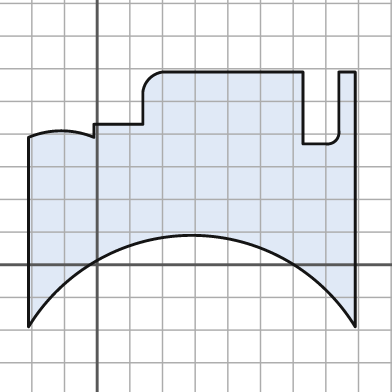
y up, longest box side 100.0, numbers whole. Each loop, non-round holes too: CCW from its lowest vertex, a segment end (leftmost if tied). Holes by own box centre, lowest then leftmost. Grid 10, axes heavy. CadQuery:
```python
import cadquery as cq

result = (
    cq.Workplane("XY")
    .moveTo(-21.0, -19.0)
    .threePointArc((29.0, 9.0), (79.0, -19.0))
    .lineTo(79.0, 59.0)
    .lineTo(74.0, 59.0)
    .lineTo(74.0, 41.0)
    .threePointArc((73.0, 38.0), (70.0, 37.0))
    .lineTo(63.0, 37.0)
    .lineTo(63.0, 59.0)
    .lineTo(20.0, 59.0)
    .threePointArc((16.0, 57.0), (14.0, 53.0))
    .lineTo(14.0, 43.0)
    .lineTo(-1.0, 43.0)
    .lineTo(-1.0, 39.0)
    .threePointArc((-11.0, 41.0), (-21.0, 39.0))
    .close()
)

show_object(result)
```